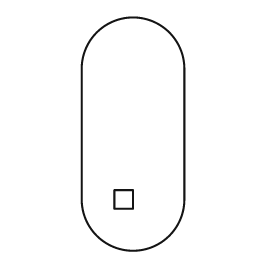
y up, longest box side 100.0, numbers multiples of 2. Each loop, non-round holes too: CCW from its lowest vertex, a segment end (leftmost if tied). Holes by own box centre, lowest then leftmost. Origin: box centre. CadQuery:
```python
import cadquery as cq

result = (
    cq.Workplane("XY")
    .moveTo(-22.0, -28.0)
    .threePointArc((0.0, -50.0), (22.0, -28.0))
    .lineTo(22.0, 28.0)
    .threePointArc((0.0, 50.0), (-22.0, 28.0))
    .close()
    .moveTo(-8.0, -32.0)
    .lineTo(0.0, -32.0)
    .lineTo(0.0, -24.0)
    .lineTo(-8.0, -24.0)
    .close()
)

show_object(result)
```